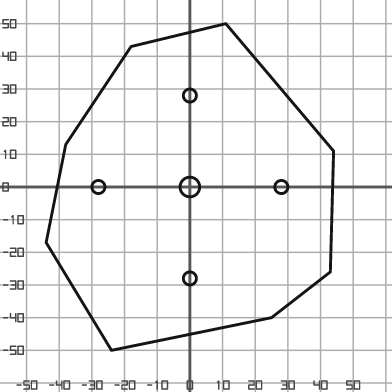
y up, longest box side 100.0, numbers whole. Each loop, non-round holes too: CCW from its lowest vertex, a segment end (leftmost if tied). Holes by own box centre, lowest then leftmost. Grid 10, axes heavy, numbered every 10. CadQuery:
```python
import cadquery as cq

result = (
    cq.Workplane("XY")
    .moveTo(-24.0, -50.0)
    .lineTo(25.0, -40.0)
    .lineTo(43.0, -26.0)
    .lineTo(44.0, 11.0)
    .lineTo(11.0, 50.0)
    .lineTo(-18.0, 43.0)
    .lineTo(-38.0, 13.0)
    .lineTo(-44.0, -17.0)
    .close()
    .moveTo(0.0, -28.0)
    .circle(2.0)
    .moveTo(-28.0, 0.0)
    .circle(2.0)
    .moveTo(0.0, 0.0)
    .circle(3.0)
    .moveTo(28.0, 0.0)
    .circle(2.0)
    .moveTo(0.0, 28.0)
    .circle(2.0)
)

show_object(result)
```